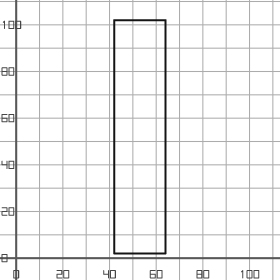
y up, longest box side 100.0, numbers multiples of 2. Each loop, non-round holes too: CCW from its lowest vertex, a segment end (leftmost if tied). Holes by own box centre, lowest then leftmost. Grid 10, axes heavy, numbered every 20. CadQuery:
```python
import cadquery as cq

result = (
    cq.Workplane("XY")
    .moveTo(42.0, 2.0)
    .lineTo(64.0, 2.0)
    .lineTo(64.0, 102.0)
    .lineTo(42.0, 102.0)
    .close()
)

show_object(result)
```